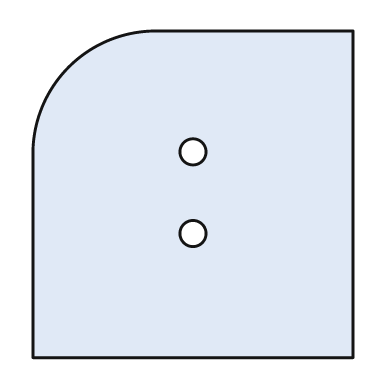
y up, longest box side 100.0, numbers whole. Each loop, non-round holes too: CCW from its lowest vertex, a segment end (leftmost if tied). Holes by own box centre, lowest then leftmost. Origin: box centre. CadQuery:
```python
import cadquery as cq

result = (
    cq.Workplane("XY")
    .moveTo(-49.0, -50.0)
    .lineTo(49.0, -50.0)
    .lineTo(49.0, 50.0)
    .lineTo(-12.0, 50.0)
    .threePointArc((-38.0, 39.0), (-49.0, 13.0))
    .close()
    .moveTo(0.0, -12.0)
    .circle(4.0)
    .moveTo(0.0, 13.0)
    .circle(4.0)
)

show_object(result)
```